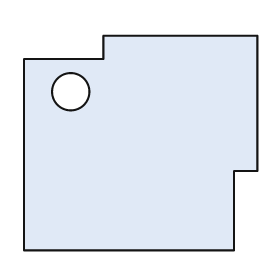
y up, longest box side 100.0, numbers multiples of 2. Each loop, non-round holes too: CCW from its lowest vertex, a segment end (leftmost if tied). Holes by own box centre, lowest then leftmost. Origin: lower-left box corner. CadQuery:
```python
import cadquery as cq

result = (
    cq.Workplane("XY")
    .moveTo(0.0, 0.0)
    .lineTo(90.0, 0.0)
    .lineTo(90.0, 34.0)
    .lineTo(100.0, 34.0)
    .lineTo(100.0, 92.0)
    .lineTo(34.0, 92.0)
    .lineTo(34.0, 82.0)
    .lineTo(0.0, 82.0)
    .close()
    .moveTo(20.0, 68.0)
    .circle(8.0)
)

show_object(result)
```